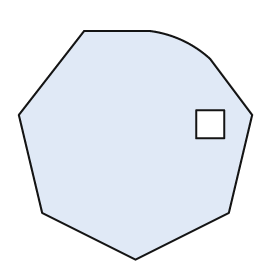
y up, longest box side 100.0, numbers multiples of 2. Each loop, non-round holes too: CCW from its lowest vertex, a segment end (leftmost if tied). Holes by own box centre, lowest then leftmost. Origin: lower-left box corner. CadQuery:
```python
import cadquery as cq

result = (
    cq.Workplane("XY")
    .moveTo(50.0, 0.0)
    .lineTo(90.0, 20.0)
    .lineTo(100.0, 62.0)
    .lineTo(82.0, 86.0)
    .threePointArc((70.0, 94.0), (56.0, 98.0))
    .lineTo(28.0, 98.0)
    .lineTo(0.0, 62.0)
    .lineTo(10.0, 20.0)
    .close()
    .moveTo(76.0, 52.0)
    .lineTo(88.0, 52.0)
    .lineTo(88.0, 64.0)
    .lineTo(76.0, 64.0)
    .close()
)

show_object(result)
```